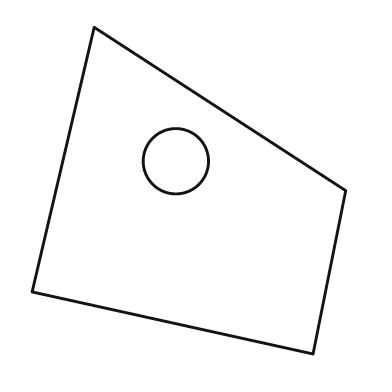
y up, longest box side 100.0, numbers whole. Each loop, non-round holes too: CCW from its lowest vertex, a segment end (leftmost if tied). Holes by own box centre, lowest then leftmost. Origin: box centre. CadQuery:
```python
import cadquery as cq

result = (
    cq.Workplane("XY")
    .moveTo(38.0, -50.0)
    .lineTo(48.0, 0.0)
    .lineTo(-29.0, 50.0)
    .lineTo(-48.0, -31.0)
    .close()
    .moveTo(-4.0, 9.0)
    .circle(10.0)
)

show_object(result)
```